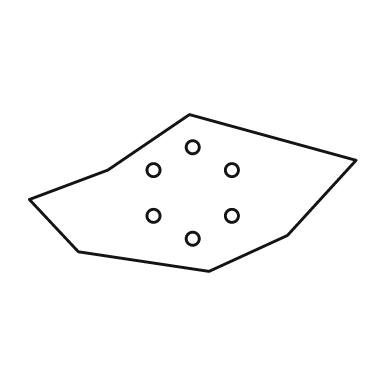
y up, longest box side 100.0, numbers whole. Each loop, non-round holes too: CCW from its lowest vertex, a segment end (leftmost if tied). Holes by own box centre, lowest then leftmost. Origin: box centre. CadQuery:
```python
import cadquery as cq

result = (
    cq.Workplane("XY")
    .moveTo(5.0, -24.0)
    .lineTo(29.0, -13.0)
    .lineTo(50.0, 10.0)
    .lineTo(-1.0, 24.0)
    .lineTo(-26.0, 7.0)
    .lineTo(-50.0, -2.0)
    .lineTo(-35.0, -18.0)
    .close()
    .moveTo(0.0, -14.0)
    .circle(2.0)
    .moveTo(-12.0, -7.0)
    .circle(2.0)
    .moveTo(12.0, -7.0)
    .circle(2.0)
    .moveTo(-12.0, 7.0)
    .circle(2.0)
    .moveTo(12.0, 7.0)
    .circle(2.0)
    .moveTo(0.0, 14.0)
    .circle(2.0)
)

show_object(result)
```